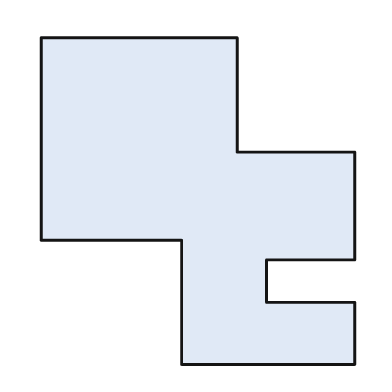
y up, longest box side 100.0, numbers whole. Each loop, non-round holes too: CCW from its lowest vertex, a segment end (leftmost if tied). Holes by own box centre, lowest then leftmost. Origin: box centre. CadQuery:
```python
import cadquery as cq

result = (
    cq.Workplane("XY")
    .moveTo(-5.0, -50.0)
    .lineTo(48.0, -50.0)
    .lineTo(48.0, -31.0)
    .lineTo(21.0, -31.0)
    .lineTo(21.0, -18.0)
    .lineTo(48.0, -18.0)
    .lineTo(48.0, 15.0)
    .lineTo(12.0, 15.0)
    .lineTo(12.0, 50.0)
    .lineTo(-48.0, 50.0)
    .lineTo(-48.0, -12.0)
    .lineTo(-5.0, -12.0)
    .close()
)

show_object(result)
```